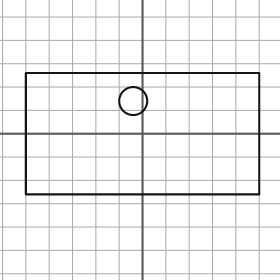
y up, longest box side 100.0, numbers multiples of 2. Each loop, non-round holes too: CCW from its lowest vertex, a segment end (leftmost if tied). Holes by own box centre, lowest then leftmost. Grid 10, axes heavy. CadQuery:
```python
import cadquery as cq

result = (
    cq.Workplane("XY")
    .moveTo(-50.0, -26.0)
    .lineTo(50.0, -26.0)
    .lineTo(50.0, 26.0)
    .lineTo(-50.0, 26.0)
    .close()
    .moveTo(-4.0, 14.0)
    .circle(6.0)
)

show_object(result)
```